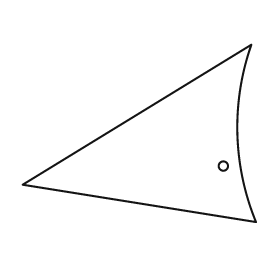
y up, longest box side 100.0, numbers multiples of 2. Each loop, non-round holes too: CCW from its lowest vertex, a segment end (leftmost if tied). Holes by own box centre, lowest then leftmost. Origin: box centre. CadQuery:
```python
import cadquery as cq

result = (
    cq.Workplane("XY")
    .moveTo(50.0, -38.0)
    .threePointArc((42.0, 0.0), (48.0, 38.0))
    .lineTo(-50.0, -22.0)
    .close()
    .moveTo(36.0, -14.0)
    .circle(2.0)
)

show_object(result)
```